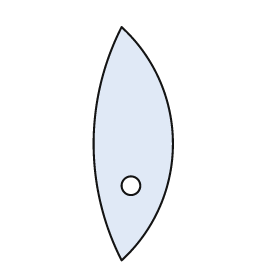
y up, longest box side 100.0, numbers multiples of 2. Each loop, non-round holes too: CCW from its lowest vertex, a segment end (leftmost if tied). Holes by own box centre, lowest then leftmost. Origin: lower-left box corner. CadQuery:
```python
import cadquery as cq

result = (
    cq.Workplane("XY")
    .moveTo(12.0, 0.0)
    .threePointArc((34.0, 50.0), (12.0, 100.0))
    .threePointArc((0.0, 50.0), (12.0, 0.0))
    .close()
    .moveTo(16.0, 32.0)
    .circle(4.0)
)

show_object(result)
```